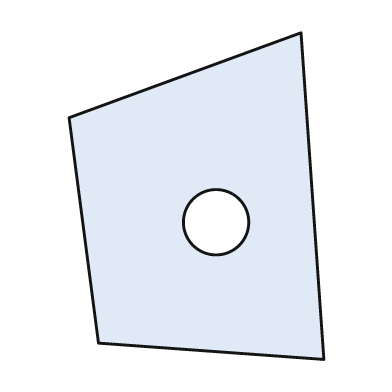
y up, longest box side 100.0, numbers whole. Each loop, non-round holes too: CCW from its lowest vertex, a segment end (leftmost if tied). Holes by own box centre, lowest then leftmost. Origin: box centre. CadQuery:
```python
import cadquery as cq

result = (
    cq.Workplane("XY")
    .moveTo(39.0, -50.0)
    .lineTo(32.0, 50.0)
    .lineTo(-39.0, 24.0)
    .lineTo(-30.0, -45.0)
    .close()
    .moveTo(6.0, -8.0)
    .circle(10.0)
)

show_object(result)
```